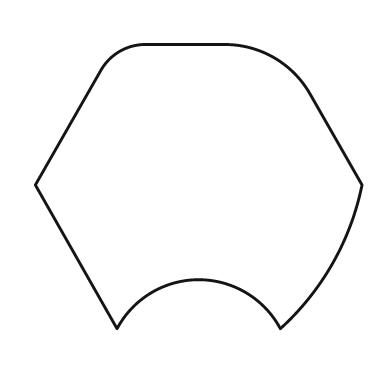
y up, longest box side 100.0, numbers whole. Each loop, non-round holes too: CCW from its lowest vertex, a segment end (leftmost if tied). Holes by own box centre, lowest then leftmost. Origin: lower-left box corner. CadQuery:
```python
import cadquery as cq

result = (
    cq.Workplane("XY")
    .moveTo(25.0, 0.0)
    .threePointArc((50.0, 15.0), (75.0, 0.0))
    .threePointArc((91.0, 20.0), (100.0, 44.0))
    .lineTo(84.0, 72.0)
    .threePointArc((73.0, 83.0), (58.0, 87.0))
    .lineTo(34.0, 87.0)
    .threePointArc((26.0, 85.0), (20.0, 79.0))
    .lineTo(0.0, 44.0)
    .close()
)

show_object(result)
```